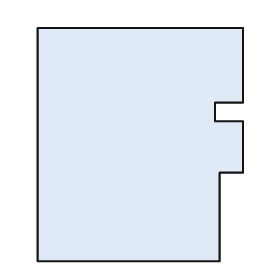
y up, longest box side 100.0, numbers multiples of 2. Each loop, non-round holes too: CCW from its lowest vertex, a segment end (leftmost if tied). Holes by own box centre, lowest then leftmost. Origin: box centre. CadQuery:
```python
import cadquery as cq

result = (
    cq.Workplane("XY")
    .moveTo(-44.0, -50.0)
    .lineTo(34.0, -50.0)
    .lineTo(34.0, -12.0)
    .lineTo(44.0, -12.0)
    .lineTo(44.0, 10.0)
    .lineTo(32.0, 10.0)
    .lineTo(32.0, 18.0)
    .lineTo(44.0, 18.0)
    .lineTo(44.0, 50.0)
    .lineTo(-44.0, 50.0)
    .close()
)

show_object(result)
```